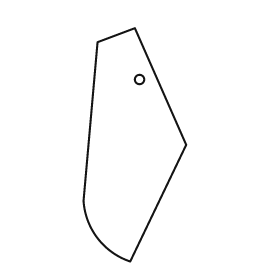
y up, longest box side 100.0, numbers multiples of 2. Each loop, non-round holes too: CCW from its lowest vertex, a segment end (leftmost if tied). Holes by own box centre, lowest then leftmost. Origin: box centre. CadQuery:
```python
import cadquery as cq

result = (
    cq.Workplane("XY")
    .moveTo(-2.0, -50.0)
    .lineTo(22.0, 0.0)
    .lineTo(0.0, 50.0)
    .lineTo(-16.0, 44.0)
    .lineTo(-22.0, -24.0)
    .threePointArc((-16.0, -40.0), (-2.0, -50.0))
    .close()
    .moveTo(2.0, 28.0)
    .circle(2.0)
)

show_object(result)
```